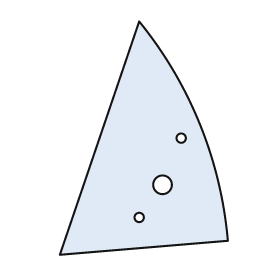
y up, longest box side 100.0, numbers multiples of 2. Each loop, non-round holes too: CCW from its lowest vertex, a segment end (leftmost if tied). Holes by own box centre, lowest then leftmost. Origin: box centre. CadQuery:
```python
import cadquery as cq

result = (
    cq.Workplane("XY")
    .moveTo(-36.0, -50.0)
    .lineTo(36.0, -44.0)
    .threePointArc((24.0, 6.0), (-2.0, 50.0))
    .close()
    .moveTo(-2.0, -34.0)
    .circle(2.0)
    .moveTo(8.0, -20.0)
    .circle(4.0)
    .moveTo(16.0, 0.0)
    .circle(2.0)
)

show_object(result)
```